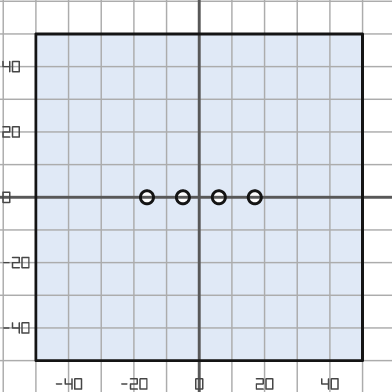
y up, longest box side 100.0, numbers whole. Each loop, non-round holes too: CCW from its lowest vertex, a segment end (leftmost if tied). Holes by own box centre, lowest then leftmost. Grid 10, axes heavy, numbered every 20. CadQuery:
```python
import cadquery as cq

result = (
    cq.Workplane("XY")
    .moveTo(-50.0, -50.0)
    .lineTo(50.0, -50.0)
    .lineTo(50.0, 50.0)
    .lineTo(-50.0, 50.0)
    .close()
    .moveTo(-16.0, 0.0)
    .circle(2.0)
    .moveTo(-5.0, 0.0)
    .circle(2.0)
    .moveTo(6.0, 0.0)
    .circle(2.0)
    .moveTo(17.0, 0.0)
    .circle(2.0)
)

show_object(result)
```